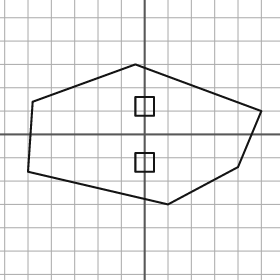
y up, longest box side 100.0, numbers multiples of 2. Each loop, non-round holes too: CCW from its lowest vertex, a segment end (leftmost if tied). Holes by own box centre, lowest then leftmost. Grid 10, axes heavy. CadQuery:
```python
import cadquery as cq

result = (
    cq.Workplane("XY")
    .moveTo(10.0, -30.0)
    .lineTo(40.0, -14.0)
    .lineTo(50.0, 10.0)
    .lineTo(-4.0, 30.0)
    .lineTo(-48.0, 14.0)
    .lineTo(-50.0, -16.0)
    .close()
    .moveTo(-4.0, -16.0)
    .lineTo(4.0, -16.0)
    .lineTo(4.0, -8.0)
    .lineTo(-4.0, -8.0)
    .close()
    .moveTo(-4.0, 8.0)
    .lineTo(4.0, 8.0)
    .lineTo(4.0, 16.0)
    .lineTo(-4.0, 16.0)
    .close()
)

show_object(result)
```